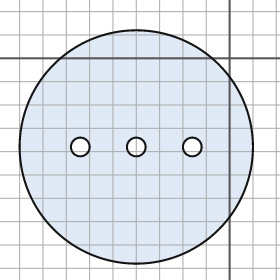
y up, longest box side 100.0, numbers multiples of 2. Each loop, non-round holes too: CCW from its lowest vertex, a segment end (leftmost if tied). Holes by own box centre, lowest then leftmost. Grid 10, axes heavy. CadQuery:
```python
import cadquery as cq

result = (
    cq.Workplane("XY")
    .moveTo(-40.0, -38.0)
    .circle(50.0)
    .moveTo(-64.0, -38.0)
    .circle(4.0)
    .moveTo(-40.0, -38.0)
    .circle(4.0)
    .moveTo(-16.0, -38.0)
    .circle(4.0)
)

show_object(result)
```